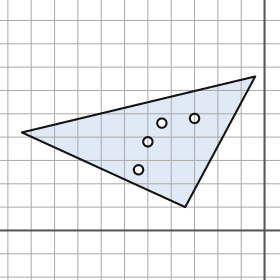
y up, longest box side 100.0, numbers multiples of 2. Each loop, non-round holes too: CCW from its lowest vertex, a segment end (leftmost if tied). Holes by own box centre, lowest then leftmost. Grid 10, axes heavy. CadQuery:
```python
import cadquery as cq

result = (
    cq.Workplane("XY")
    .moveTo(-34.0, 10.0)
    .lineTo(-4.0, 66.0)
    .lineTo(-104.0, 42.0)
    .close()
    .moveTo(-54.0, 26.0)
    .circle(2.0)
    .moveTo(-50.0, 38.0)
    .circle(2.0)
    .moveTo(-44.0, 46.0)
    .circle(2.0)
    .moveTo(-30.0, 48.0)
    .circle(2.0)
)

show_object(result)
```